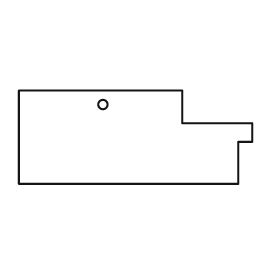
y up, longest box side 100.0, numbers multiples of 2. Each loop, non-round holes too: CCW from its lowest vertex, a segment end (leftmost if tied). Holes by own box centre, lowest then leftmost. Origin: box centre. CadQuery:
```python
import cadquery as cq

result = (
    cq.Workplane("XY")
    .moveTo(-50.0, -20.0)
    .lineTo(44.0, -20.0)
    .lineTo(44.0, -2.0)
    .lineTo(50.0, -2.0)
    .lineTo(50.0, 6.0)
    .lineTo(20.0, 6.0)
    .lineTo(20.0, 20.0)
    .lineTo(-50.0, 20.0)
    .close()
    .moveTo(-14.0, 14.0)
    .circle(2.0)
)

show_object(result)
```